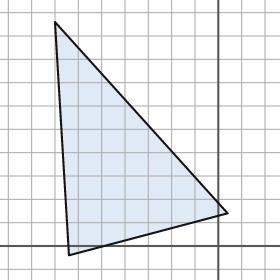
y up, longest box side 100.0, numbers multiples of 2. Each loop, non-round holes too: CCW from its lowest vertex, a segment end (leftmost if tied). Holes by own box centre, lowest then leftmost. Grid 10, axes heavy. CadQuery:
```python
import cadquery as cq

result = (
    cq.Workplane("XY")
    .moveTo(-64.0, -4.0)
    .lineTo(4.0, 14.0)
    .lineTo(-70.0, 96.0)
    .close()
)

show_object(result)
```